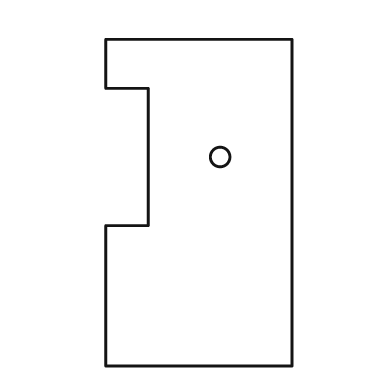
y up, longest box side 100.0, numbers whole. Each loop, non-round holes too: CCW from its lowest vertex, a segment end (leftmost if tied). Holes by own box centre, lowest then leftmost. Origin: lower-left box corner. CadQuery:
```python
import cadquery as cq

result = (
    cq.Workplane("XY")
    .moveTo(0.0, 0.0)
    .lineTo(57.0, 0.0)
    .lineTo(57.0, 100.0)
    .lineTo(0.0, 100.0)
    .lineTo(0.0, 85.0)
    .lineTo(13.0, 85.0)
    .lineTo(13.0, 43.0)
    .lineTo(0.0, 43.0)
    .close()
    .moveTo(35.0, 64.0)
    .circle(3.0)
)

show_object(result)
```